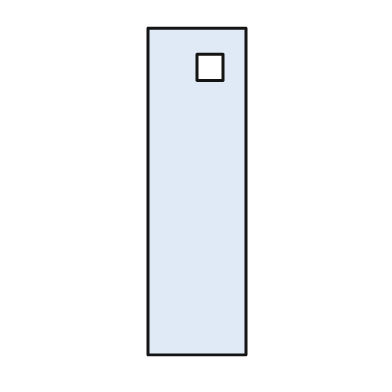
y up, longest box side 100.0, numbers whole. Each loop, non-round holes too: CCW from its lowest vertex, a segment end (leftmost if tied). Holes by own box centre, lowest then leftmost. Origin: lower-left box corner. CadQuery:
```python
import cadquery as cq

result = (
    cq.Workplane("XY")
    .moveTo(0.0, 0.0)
    .lineTo(30.0, 0.0)
    .lineTo(30.0, 100.0)
    .lineTo(0.0, 100.0)
    .close()
    .moveTo(15.0, 84.0)
    .lineTo(23.0, 84.0)
    .lineTo(23.0, 92.0)
    .lineTo(15.0, 92.0)
    .close()
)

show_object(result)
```